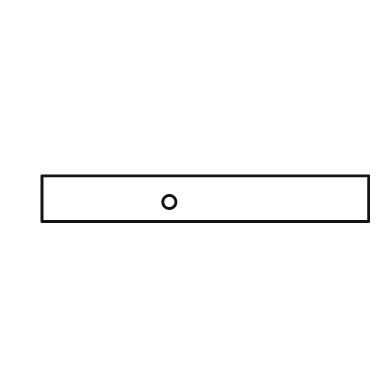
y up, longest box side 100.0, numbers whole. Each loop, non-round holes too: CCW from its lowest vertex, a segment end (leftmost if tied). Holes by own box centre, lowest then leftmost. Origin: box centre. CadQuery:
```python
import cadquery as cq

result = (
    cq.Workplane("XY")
    .moveTo(-50.0, -7.0)
    .lineTo(50.0, -7.0)
    .lineTo(50.0, 7.0)
    .lineTo(-50.0, 7.0)
    .close()
    .moveTo(-11.0, -1.0)
    .circle(2.0)
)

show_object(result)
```